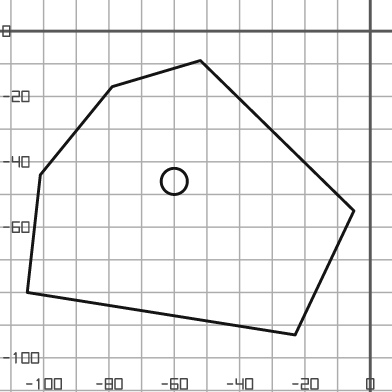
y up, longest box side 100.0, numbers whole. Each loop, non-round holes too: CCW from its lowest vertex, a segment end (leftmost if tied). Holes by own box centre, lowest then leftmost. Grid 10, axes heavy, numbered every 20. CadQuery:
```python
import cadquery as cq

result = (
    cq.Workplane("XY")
    .moveTo(-23.0, -93.0)
    .lineTo(-5.0, -55.0)
    .lineTo(-52.0, -9.0)
    .lineTo(-79.0, -17.0)
    .lineTo(-101.0, -44.0)
    .lineTo(-105.0, -80.0)
    .close()
    .moveTo(-60.0, -46.0)
    .circle(4.0)
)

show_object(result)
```